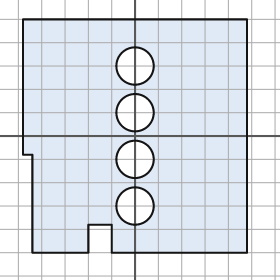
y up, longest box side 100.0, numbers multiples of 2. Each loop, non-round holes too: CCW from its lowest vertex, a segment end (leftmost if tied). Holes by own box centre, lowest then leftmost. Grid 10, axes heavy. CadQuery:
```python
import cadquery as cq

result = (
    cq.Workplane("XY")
    .moveTo(-44.0, -50.0)
    .lineTo(-20.0, -50.0)
    .lineTo(-20.0, -38.0)
    .lineTo(-10.0, -38.0)
    .lineTo(-10.0, -50.0)
    .lineTo(48.0, -50.0)
    .lineTo(48.0, 50.0)
    .lineTo(-48.0, 50.0)
    .lineTo(-48.0, -8.0)
    .lineTo(-44.0, -8.0)
    .close()
    .moveTo(0.0, -30.0)
    .circle(8.0)
    .moveTo(0.0, -10.0)
    .circle(8.0)
    .moveTo(0.0, 10.0)
    .circle(8.0)
    .moveTo(0.0, 30.0)
    .circle(8.0)
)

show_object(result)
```